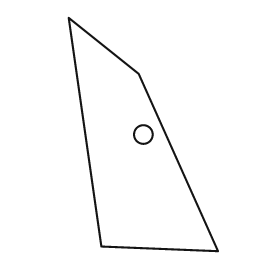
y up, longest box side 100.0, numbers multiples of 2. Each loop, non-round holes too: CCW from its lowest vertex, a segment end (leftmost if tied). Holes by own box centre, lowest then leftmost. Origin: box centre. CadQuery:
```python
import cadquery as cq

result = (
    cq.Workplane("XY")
    .moveTo(32.0, -50.0)
    .lineTo(-2.0, 26.0)
    .lineTo(-32.0, 50.0)
    .lineTo(-18.0, -48.0)
    .close()
    .moveTo(0.0, 0.0)
    .circle(4.0)
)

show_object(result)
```